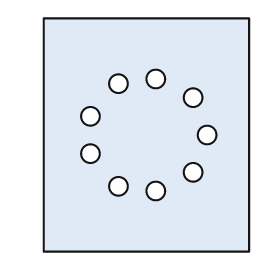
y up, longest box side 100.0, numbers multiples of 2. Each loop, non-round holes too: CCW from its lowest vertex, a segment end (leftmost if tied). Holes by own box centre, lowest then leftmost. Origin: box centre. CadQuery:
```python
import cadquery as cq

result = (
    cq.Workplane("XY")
    .moveTo(-44.0, -50.0)
    .lineTo(44.0, -50.0)
    .lineTo(44.0, 50.0)
    .lineTo(-44.0, 50.0)
    .close()
    .moveTo(4.0, -24.0)
    .circle(4.0)
    .moveTo(-12.0, -22.0)
    .circle(4.0)
    .moveTo(20.0, -16.0)
    .circle(4.0)
    .moveTo(-24.0, -8.0)
    .circle(4.0)
    .moveTo(26.0, 0.0)
    .circle(4.0)
    .moveTo(-24.0, 8.0)
    .circle(4.0)
    .moveTo(20.0, 16.0)
    .circle(4.0)
    .moveTo(-12.0, 22.0)
    .circle(4.0)
    .moveTo(4.0, 24.0)
    .circle(4.0)
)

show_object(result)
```